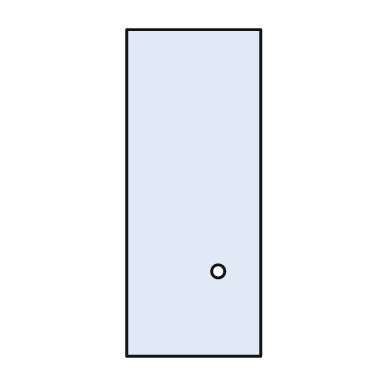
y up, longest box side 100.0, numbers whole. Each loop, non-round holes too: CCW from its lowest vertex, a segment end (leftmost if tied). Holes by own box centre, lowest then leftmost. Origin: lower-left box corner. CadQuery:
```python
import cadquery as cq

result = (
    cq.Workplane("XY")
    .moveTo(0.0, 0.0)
    .lineTo(41.0, 0.0)
    .lineTo(41.0, 100.0)
    .lineTo(0.0, 100.0)
    .close()
    .moveTo(28.0, 26.0)
    .circle(2.0)
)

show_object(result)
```